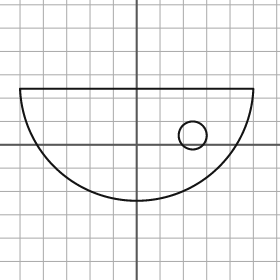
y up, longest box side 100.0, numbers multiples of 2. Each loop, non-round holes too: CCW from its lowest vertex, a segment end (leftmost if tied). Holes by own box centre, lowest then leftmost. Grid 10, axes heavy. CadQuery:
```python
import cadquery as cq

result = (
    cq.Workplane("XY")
    .moveTo(-50.0, 24.0)
    .threePointArc((0.0, -24.0), (50.0, 24.0))
    .close()
    .moveTo(24.0, 4.0)
    .circle(6.0)
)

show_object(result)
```